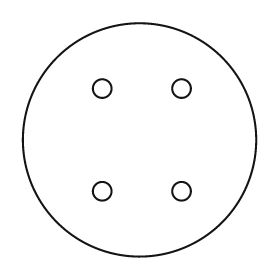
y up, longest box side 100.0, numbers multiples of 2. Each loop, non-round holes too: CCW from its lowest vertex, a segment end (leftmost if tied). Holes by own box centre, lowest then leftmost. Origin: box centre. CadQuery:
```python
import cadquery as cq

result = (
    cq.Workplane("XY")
    .moveTo(0.0, 0.0)
    .circle(50.0)
    .moveTo(-16.0, -22.0)
    .circle(4.0)
    .moveTo(18.0, -22.0)
    .circle(4.0)
    .moveTo(-16.0, 22.0)
    .circle(4.0)
    .moveTo(18.0, 22.0)
    .circle(4.0)
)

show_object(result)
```